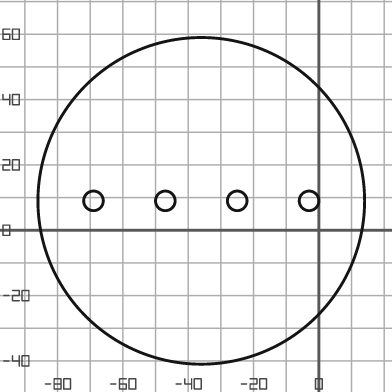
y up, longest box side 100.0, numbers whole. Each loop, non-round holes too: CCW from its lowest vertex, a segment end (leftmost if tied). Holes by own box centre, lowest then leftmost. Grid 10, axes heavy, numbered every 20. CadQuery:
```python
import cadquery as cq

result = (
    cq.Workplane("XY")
    .moveTo(-36.0, 9.0)
    .circle(50.0)
    .moveTo(-69.0, 9.0)
    .circle(3.0)
    .moveTo(-47.0, 9.0)
    .circle(3.0)
    .moveTo(-25.0, 9.0)
    .circle(3.0)
    .moveTo(-3.0, 9.0)
    .circle(3.0)
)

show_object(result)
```